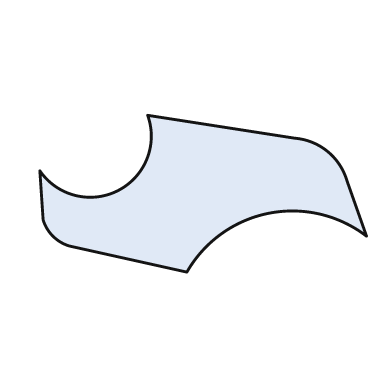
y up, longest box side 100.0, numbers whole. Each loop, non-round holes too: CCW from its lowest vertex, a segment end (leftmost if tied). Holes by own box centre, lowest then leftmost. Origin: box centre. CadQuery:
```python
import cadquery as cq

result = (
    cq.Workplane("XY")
    .moveTo(-5.0, -24.0)
    .threePointArc((20.0, -6.0), (50.0, -13.0))
    .lineTo(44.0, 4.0)
    .threePointArc((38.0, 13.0), (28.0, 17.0))
    .lineTo(-17.0, 24.0)
    .threePointArc((-26.0, 1.0), (-50.0, 7.0))
    .lineTo(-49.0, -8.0)
    .threePointArc((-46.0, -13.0), (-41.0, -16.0))
    .close()
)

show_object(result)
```